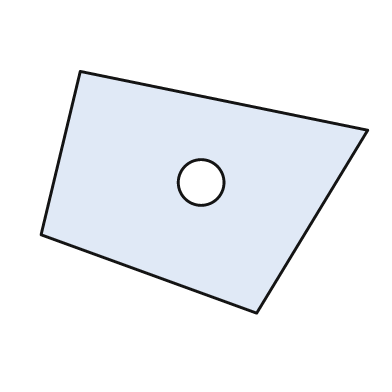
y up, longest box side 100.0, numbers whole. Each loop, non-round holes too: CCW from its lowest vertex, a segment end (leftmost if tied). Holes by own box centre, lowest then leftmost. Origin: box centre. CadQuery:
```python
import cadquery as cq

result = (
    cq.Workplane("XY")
    .moveTo(16.0, -37.0)
    .lineTo(50.0, 19.0)
    .lineTo(-38.0, 37.0)
    .lineTo(-50.0, -13.0)
    .close()
    .moveTo(-1.0, 3.0)
    .circle(7.0)
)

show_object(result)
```